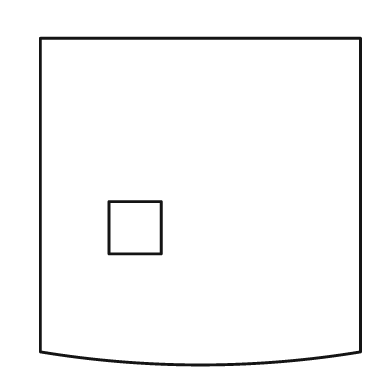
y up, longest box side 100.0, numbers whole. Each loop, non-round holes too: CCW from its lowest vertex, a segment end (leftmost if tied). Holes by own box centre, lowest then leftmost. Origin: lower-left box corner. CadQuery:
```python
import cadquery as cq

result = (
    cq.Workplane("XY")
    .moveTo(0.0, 4.0)
    .threePointArc((49.0, 0.0), (98.0, 4.0))
    .lineTo(98.0, 100.0)
    .lineTo(0.0, 100.0)
    .close()
    .moveTo(21.0, 34.0)
    .lineTo(37.0, 34.0)
    .lineTo(37.0, 50.0)
    .lineTo(21.0, 50.0)
    .close()
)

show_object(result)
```